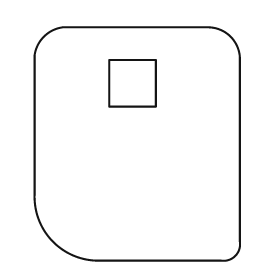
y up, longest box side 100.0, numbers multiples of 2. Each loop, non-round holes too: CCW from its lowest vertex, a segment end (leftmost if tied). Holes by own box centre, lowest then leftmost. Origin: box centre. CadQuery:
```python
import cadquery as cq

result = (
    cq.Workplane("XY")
    .moveTo(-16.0, -50.0)
    .lineTo(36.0, -50.0)
    .threePointArc((42.0, -48.0), (44.0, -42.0))
    .lineTo(44.0, 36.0)
    .threePointArc((40.0, 46.0), (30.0, 50.0))
    .lineTo(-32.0, 50.0)
    .threePointArc((-40.0, 46.0), (-44.0, 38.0))
    .lineTo(-44.0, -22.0)
    .threePointArc((-36.0, -42.0), (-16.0, -50.0))
    .close()
    .moveTo(-12.0, 16.0)
    .lineTo(8.0, 16.0)
    .lineTo(8.0, 36.0)
    .lineTo(-12.0, 36.0)
    .close()
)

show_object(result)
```